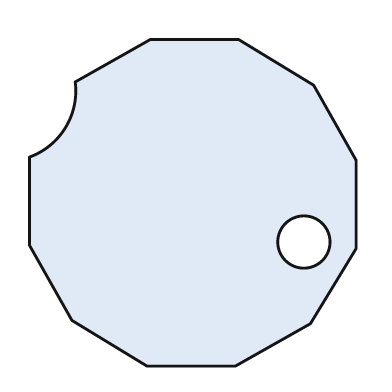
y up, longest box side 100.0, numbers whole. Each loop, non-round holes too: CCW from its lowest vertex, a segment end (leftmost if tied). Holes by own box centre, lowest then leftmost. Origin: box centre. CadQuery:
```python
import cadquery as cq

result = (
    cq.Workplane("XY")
    .moveTo(-14.0, -50.0)
    .lineTo(13.0, -50.0)
    .lineTo(36.0, -37.0)
    .lineTo(50.0, -14.0)
    .lineTo(50.0, 13.0)
    .lineTo(37.0, 36.0)
    .lineTo(14.0, 50.0)
    .lineTo(-13.0, 50.0)
    .lineTo(-36.0, 37.0)
    .threePointArc((-39.0, 23.0), (-50.0, 14.0))
    .lineTo(-50.0, -13.0)
    .lineTo(-37.0, -36.0)
    .close()
    .moveTo(34.0, -12.0)
    .circle(8.0)
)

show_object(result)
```